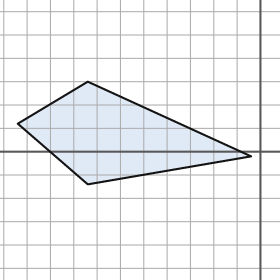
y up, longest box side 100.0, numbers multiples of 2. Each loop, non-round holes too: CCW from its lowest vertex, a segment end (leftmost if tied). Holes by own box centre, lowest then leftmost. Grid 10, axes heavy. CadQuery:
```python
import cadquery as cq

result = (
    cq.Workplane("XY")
    .moveTo(-74.0, -14.0)
    .lineTo(-4.0, -2.0)
    .lineTo(-74.0, 30.0)
    .lineTo(-104.0, 12.0)
    .close()
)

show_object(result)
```